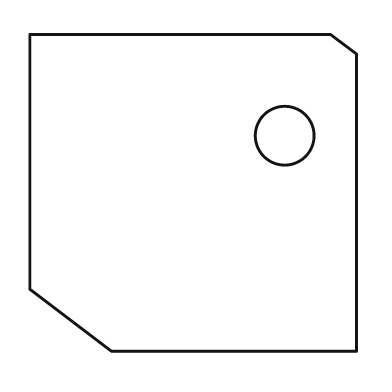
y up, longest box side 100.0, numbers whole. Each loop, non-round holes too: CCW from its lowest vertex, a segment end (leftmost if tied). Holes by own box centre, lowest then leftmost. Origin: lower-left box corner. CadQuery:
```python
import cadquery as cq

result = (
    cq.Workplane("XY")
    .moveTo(25.0, 0.0)
    .lineTo(100.0, 0.0)
    .lineTo(100.0, 91.0)
    .lineTo(92.0, 97.0)
    .lineTo(0.0, 97.0)
    .lineTo(0.0, 19.0)
    .close()
    .moveTo(78.0, 66.0)
    .circle(9.0)
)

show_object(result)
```